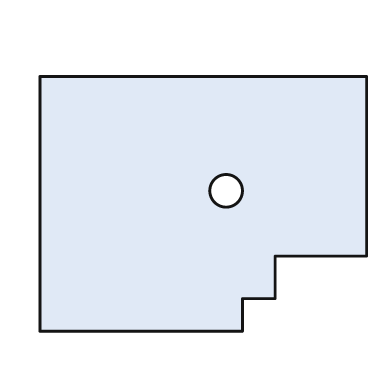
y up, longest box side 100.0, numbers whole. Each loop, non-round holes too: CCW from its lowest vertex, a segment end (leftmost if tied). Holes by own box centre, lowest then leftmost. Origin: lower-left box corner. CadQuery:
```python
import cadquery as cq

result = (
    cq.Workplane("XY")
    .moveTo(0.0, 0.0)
    .lineTo(62.0, 0.0)
    .lineTo(62.0, 10.0)
    .lineTo(72.0, 10.0)
    .lineTo(72.0, 23.0)
    .lineTo(100.0, 23.0)
    .lineTo(100.0, 78.0)
    .lineTo(0.0, 78.0)
    .close()
    .moveTo(57.0, 43.0)
    .circle(5.0)
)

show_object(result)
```